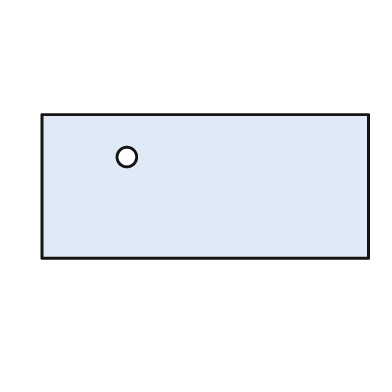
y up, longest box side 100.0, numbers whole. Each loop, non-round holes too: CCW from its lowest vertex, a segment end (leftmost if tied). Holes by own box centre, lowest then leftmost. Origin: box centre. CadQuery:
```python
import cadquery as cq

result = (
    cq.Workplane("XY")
    .moveTo(-50.0, -22.0)
    .lineTo(50.0, -22.0)
    .lineTo(50.0, 22.0)
    .lineTo(-50.0, 22.0)
    .close()
    .moveTo(-24.0, 9.0)
    .circle(3.0)
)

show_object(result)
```